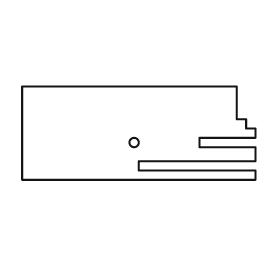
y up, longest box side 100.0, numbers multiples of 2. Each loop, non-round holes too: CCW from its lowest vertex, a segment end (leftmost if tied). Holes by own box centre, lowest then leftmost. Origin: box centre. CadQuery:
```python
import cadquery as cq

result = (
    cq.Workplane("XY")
    .moveTo(-50.0, -20.0)
    .lineTo(50.0, -20.0)
    .lineTo(50.0, -16.0)
    .lineTo(0.0, -16.0)
    .lineTo(0.0, -12.0)
    .lineTo(50.0, -12.0)
    .lineTo(50.0, -6.0)
    .lineTo(26.0, -6.0)
    .lineTo(26.0, -2.0)
    .lineTo(50.0, -2.0)
    .lineTo(50.0, 2.0)
    .lineTo(46.0, 2.0)
    .lineTo(46.0, 6.0)
    .lineTo(42.0, 6.0)
    .lineTo(42.0, 20.0)
    .lineTo(-50.0, 20.0)
    .close()
    .moveTo(-2.0, -4.0)
    .circle(2.0)
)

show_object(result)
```